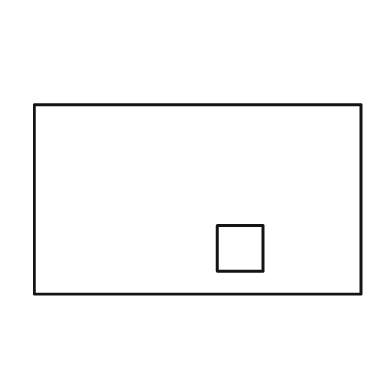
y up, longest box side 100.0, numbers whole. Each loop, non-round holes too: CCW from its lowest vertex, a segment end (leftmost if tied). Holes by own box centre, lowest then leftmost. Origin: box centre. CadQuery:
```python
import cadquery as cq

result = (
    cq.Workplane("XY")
    .moveTo(-50.0, -29.0)
    .lineTo(50.0, -29.0)
    .lineTo(50.0, 29.0)
    .lineTo(-50.0, 29.0)
    .close()
    .moveTo(6.0, -22.0)
    .lineTo(20.0, -22.0)
    .lineTo(20.0, -8.0)
    .lineTo(6.0, -8.0)
    .close()
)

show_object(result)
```